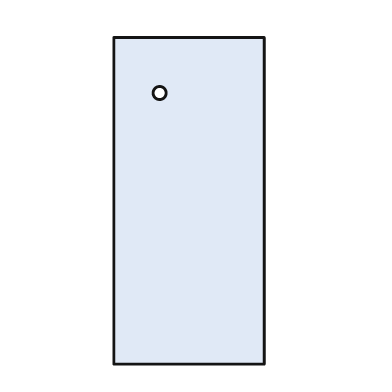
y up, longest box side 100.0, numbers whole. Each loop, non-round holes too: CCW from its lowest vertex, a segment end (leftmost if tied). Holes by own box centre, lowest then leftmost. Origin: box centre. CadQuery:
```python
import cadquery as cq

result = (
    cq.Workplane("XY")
    .moveTo(-23.0, -50.0)
    .lineTo(23.0, -50.0)
    .lineTo(23.0, 50.0)
    .lineTo(-23.0, 50.0)
    .close()
    .moveTo(-9.0, 33.0)
    .circle(2.0)
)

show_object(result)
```